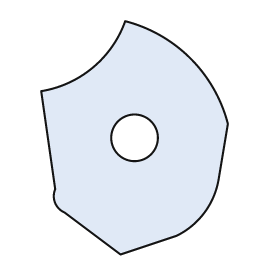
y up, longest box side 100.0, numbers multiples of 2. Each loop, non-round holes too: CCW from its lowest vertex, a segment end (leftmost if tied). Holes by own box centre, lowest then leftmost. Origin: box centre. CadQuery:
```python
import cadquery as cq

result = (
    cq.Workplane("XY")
    .moveTo(-6.0, -50.0)
    .lineTo(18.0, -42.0)
    .threePointArc((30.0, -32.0), (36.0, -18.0))
    .lineTo(40.0, 6.0)
    .threePointArc((24.0, 34.0), (-4.0, 50.0))
    .threePointArc((-18.0, 30.0), (-40.0, 20.0))
    .lineTo(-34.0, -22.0)
    .threePointArc((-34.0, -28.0), (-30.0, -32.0))
    .close()
    .moveTo(0.0, 0.0)
    .circle(10.0)
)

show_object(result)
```